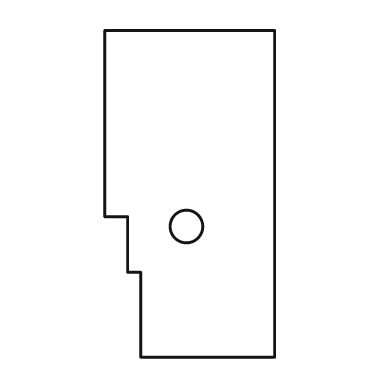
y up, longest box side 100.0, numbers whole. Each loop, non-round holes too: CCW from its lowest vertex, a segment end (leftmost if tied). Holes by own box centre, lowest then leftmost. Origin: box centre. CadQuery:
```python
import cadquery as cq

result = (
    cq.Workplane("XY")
    .moveTo(-15.0, -50.0)
    .lineTo(26.0, -50.0)
    .lineTo(26.0, 50.0)
    .lineTo(-26.0, 50.0)
    .lineTo(-26.0, -7.0)
    .lineTo(-19.0, -7.0)
    .lineTo(-19.0, -24.0)
    .lineTo(-15.0, -24.0)
    .close()
    .moveTo(-1.0, -10.0)
    .circle(5.0)
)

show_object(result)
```